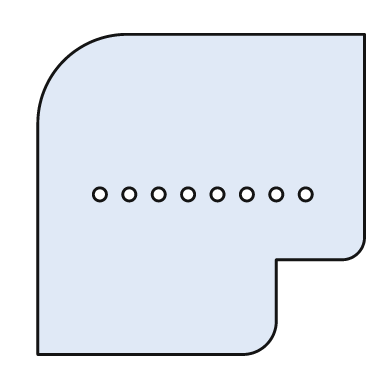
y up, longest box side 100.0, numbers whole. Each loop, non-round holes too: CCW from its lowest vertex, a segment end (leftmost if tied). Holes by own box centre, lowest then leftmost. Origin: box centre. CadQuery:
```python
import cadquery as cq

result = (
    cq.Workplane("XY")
    .moveTo(-50.0, -49.0)
    .lineTo(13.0, -49.0)
    .threePointArc((20.0, -46.0), (23.0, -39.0))
    .lineTo(23.0, -20.0)
    .lineTo(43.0, -20.0)
    .threePointArc((48.0, -18.0), (50.0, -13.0))
    .lineTo(50.0, 49.0)
    .lineTo(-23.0, 49.0)
    .threePointArc((-42.0, 41.0), (-50.0, 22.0))
    .close()
    .moveTo(-31.0, 0.0)
    .circle(2.0)
    .moveTo(-22.0, 0.0)
    .circle(2.0)
    .moveTo(-13.0, 0.0)
    .circle(2.0)
    .moveTo(-4.0, 0.0)
    .circle(2.0)
    .moveTo(5.0, 0.0)
    .circle(2.0)
    .moveTo(14.0, 0.0)
    .circle(2.0)
    .moveTo(23.0, 0.0)
    .circle(2.0)
    .moveTo(32.0, 0.0)
    .circle(2.0)
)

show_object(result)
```